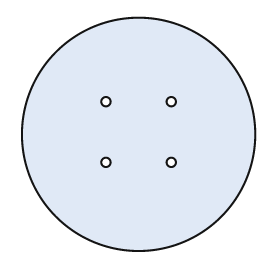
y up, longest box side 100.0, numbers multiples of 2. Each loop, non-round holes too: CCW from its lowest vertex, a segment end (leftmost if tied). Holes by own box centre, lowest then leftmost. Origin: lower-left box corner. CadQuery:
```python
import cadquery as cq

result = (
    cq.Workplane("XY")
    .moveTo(50.0, 50.0)
    .circle(50.0)
    .moveTo(36.0, 38.0)
    .circle(2.0)
    .moveTo(64.0, 38.0)
    .circle(2.0)
    .moveTo(36.0, 64.0)
    .circle(2.0)
    .moveTo(64.0, 64.0)
    .circle(2.0)
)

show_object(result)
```